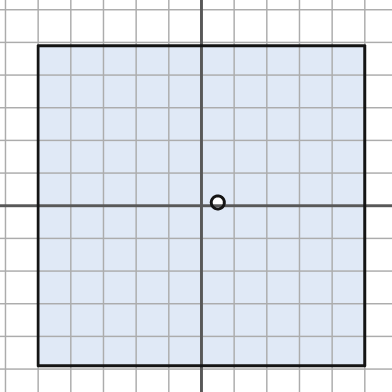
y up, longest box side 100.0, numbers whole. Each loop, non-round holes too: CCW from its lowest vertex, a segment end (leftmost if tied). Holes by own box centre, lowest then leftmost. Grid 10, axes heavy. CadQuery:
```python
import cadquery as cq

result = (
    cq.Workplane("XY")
    .moveTo(-50.0, -49.0)
    .lineTo(50.0, -49.0)
    .lineTo(50.0, 49.0)
    .lineTo(-50.0, 49.0)
    .close()
    .moveTo(5.0, 1.0)
    .circle(2.0)
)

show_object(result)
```